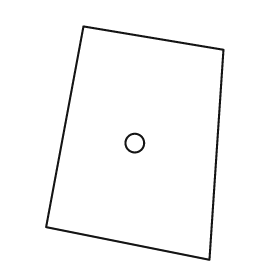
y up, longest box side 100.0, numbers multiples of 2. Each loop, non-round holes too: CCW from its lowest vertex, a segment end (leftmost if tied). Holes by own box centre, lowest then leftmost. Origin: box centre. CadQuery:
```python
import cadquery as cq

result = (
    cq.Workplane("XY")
    .moveTo(32.0, -50.0)
    .lineTo(38.0, 40.0)
    .lineTo(-22.0, 50.0)
    .lineTo(-38.0, -36.0)
    .close()
    .moveTo(0.0, 0.0)
    .circle(4.0)
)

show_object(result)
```